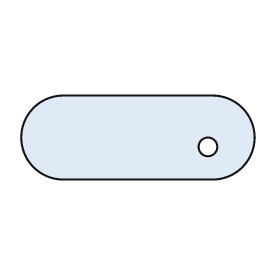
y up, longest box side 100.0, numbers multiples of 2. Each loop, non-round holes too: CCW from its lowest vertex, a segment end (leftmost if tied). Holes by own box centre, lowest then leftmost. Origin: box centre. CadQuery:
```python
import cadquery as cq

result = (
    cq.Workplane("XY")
    .moveTo(-32.0, -18.0)
    .lineTo(32.0, -18.0)
    .threePointArc((50.0, 0.0), (32.0, 18.0))
    .lineTo(-32.0, 18.0)
    .threePointArc((-50.0, 0.0), (-32.0, -18.0))
    .close()
    .moveTo(30.0, -4.0)
    .circle(4.0)
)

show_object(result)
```